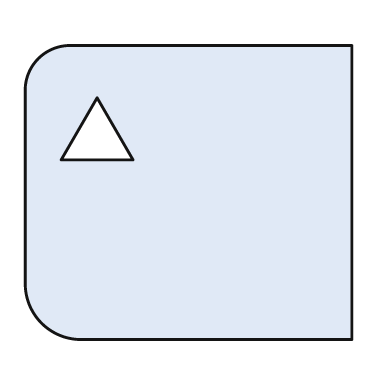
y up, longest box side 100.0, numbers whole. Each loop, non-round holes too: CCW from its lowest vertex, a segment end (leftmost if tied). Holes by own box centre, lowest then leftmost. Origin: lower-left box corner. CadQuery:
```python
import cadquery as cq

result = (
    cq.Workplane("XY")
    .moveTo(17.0, 0.0)
    .lineTo(100.0, 0.0)
    .lineTo(100.0, 90.0)
    .lineTo(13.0, 90.0)
    .threePointArc((4.0, 86.0), (0.0, 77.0))
    .lineTo(0.0, 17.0)
    .threePointArc((5.0, 5.0), (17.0, 0.0))
    .close()
    .moveTo(11.0, 55.0)
    .lineTo(33.0, 55.0)
    .lineTo(22.0, 74.0)
    .close()
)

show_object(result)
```